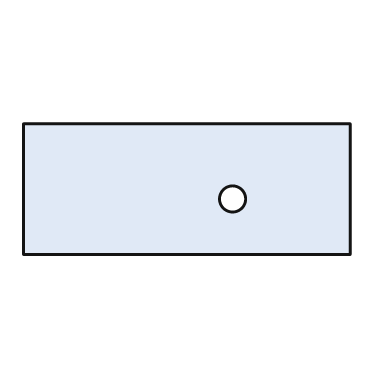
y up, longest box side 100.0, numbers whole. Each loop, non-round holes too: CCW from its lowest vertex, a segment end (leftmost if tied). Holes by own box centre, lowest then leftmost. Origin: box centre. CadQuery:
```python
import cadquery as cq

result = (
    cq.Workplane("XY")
    .moveTo(-50.0, -20.0)
    .lineTo(50.0, -20.0)
    .lineTo(50.0, 20.0)
    .lineTo(-50.0, 20.0)
    .close()
    .moveTo(14.0, -3.0)
    .circle(4.0)
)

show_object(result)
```